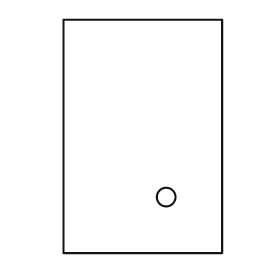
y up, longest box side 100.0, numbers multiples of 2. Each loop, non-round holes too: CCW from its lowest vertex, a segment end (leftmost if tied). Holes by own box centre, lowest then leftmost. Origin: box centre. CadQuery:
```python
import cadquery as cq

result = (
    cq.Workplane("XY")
    .moveTo(-34.0, -50.0)
    .lineTo(34.0, -50.0)
    .lineTo(34.0, 50.0)
    .lineTo(-34.0, 50.0)
    .close()
    .moveTo(10.0, -26.0)
    .circle(4.0)
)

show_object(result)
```